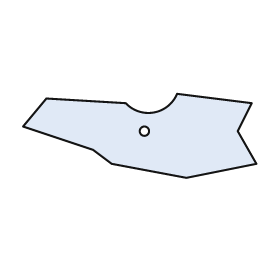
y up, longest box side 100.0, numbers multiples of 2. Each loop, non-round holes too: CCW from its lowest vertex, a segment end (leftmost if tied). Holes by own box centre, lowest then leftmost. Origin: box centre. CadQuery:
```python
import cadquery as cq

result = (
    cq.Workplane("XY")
    .moveTo(20.0, -18.0)
    .lineTo(50.0, -12.0)
    .lineTo(42.0, 2.0)
    .lineTo(48.0, 14.0)
    .lineTo(16.0, 18.0)
    .threePointArc((6.0, 10.0), (-6.0, 14.0))
    .lineTo(-40.0, 16.0)
    .lineTo(-50.0, 4.0)
    .lineTo(-20.0, -6.0)
    .lineTo(-12.0, -12.0)
    .close()
    .moveTo(2.0, 2.0)
    .circle(2.0)
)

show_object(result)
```